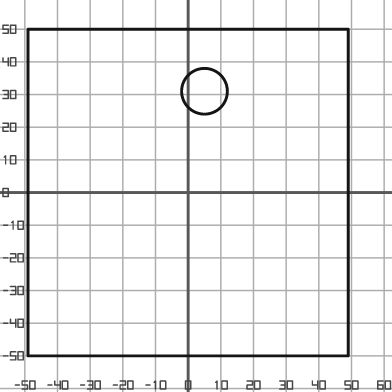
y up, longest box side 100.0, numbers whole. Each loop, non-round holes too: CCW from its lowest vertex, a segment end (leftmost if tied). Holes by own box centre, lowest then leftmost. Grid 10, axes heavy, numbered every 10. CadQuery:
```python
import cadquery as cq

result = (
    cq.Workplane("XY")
    .moveTo(-49.0, -50.0)
    .lineTo(49.0, -50.0)
    .lineTo(49.0, 50.0)
    .lineTo(-49.0, 50.0)
    .close()
    .moveTo(5.0, 31.0)
    .circle(7.0)
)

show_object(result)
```